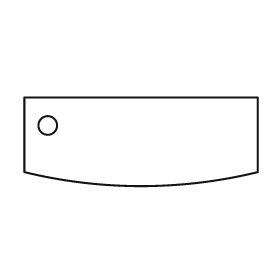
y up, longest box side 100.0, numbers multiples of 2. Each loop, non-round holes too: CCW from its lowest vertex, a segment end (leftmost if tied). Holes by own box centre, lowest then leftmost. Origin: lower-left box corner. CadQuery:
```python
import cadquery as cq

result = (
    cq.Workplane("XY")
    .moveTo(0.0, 6.0)
    .threePointArc((50.0, 0.0), (100.0, 6.0))
    .lineTo(100.0, 38.0)
    .lineTo(0.0, 38.0)
    .close()
    .moveTo(10.0, 26.0)
    .circle(4.0)
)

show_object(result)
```